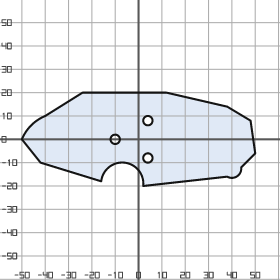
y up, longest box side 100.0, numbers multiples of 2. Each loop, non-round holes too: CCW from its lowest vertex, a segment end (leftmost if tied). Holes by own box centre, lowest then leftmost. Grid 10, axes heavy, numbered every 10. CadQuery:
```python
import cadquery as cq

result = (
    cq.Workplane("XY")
    .moveTo(2.0, -20.0)
    .lineTo(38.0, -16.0)
    .threePointArc((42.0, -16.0), (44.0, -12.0))
    .lineTo(50.0, -6.0)
    .lineTo(48.0, 8.0)
    .lineTo(38.0, 14.0)
    .lineTo(12.0, 20.0)
    .lineTo(-24.0, 20.0)
    .lineTo(-40.0, 10.0)
    .threePointArc((-46.0, 6.0), (-50.0, 0.0))
    .lineTo(-42.0, -10.0)
    .lineTo(-16.0, -18.0)
    .threePointArc((-6.0, -10.0), (2.0, -20.0))
    .close()
    .moveTo(4.0, -8.0)
    .circle(2.0)
    .moveTo(-10.0, 0.0)
    .circle(2.0)
    .moveTo(4.0, 8.0)
    .circle(2.0)
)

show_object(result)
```